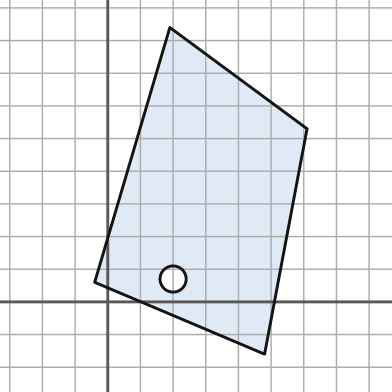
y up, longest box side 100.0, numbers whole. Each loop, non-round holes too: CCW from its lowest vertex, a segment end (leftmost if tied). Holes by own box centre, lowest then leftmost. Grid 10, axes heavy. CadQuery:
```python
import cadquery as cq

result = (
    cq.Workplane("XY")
    .moveTo(48.0, -16.0)
    .lineTo(61.0, 53.0)
    .lineTo(19.0, 84.0)
    .lineTo(-4.0, 6.0)
    .close()
    .moveTo(20.0, 7.0)
    .circle(4.0)
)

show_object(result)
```